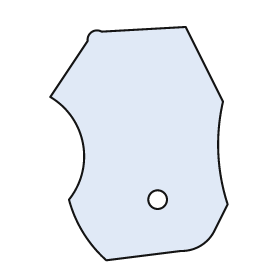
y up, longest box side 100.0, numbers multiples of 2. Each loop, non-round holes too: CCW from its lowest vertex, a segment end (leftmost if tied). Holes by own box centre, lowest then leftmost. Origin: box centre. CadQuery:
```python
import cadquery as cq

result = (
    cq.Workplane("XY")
    .moveTo(-14.0, -50.0)
    .lineTo(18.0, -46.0)
    .threePointArc((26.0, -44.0), (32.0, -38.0))
    .lineTo(38.0, -26.0)
    .threePointArc((34.0, -4.0), (36.0, 18.0))
    .lineTo(20.0, 50.0)
    .lineTo(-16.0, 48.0)
    .threePointArc((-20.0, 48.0), (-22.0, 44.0))
    .lineTo(-38.0, 20.0)
    .threePointArc((-24.0, 0.0), (-30.0, -24.0))
    .threePointArc((-24.0, -38.0), (-14.0, -50.0))
    .close()
    .moveTo(8.0, -24.0)
    .circle(4.0)
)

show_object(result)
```